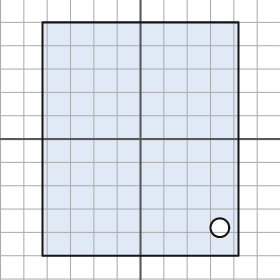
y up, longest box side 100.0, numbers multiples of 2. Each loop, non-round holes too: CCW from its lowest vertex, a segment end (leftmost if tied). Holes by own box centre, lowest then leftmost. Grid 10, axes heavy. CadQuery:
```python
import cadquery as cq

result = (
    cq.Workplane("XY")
    .moveTo(-42.0, -50.0)
    .lineTo(42.0, -50.0)
    .lineTo(42.0, 50.0)
    .lineTo(-42.0, 50.0)
    .close()
    .moveTo(34.0, -38.0)
    .circle(4.0)
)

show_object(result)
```